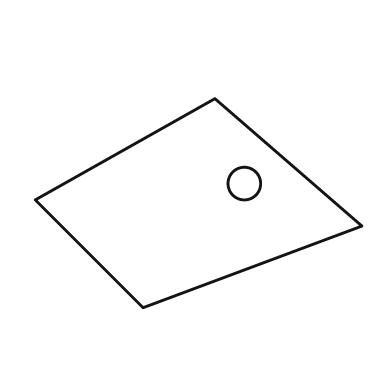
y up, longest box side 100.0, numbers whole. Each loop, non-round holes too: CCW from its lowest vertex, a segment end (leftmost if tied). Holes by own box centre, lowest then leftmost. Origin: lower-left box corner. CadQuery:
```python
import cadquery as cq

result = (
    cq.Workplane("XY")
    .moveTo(33.0, 0.0)
    .lineTo(100.0, 25.0)
    .lineTo(55.0, 64.0)
    .lineTo(0.0, 33.0)
    .close()
    .moveTo(64.0, 38.0)
    .circle(5.0)
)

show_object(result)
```